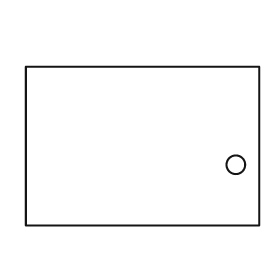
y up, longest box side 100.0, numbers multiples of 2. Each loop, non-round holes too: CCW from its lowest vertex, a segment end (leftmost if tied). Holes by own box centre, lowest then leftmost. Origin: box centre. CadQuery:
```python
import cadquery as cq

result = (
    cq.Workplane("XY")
    .moveTo(-50.0, -34.0)
    .lineTo(50.0, -34.0)
    .lineTo(50.0, 34.0)
    .lineTo(-50.0, 34.0)
    .close()
    .moveTo(40.0, -8.0)
    .circle(4.0)
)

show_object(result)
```